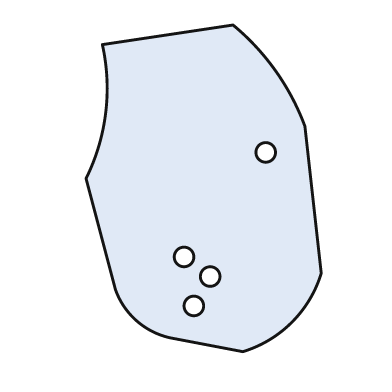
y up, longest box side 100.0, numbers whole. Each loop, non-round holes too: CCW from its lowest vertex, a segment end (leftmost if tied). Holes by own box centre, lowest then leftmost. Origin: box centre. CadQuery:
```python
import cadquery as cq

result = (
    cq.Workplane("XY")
    .moveTo(12.0, -50.0)
    .threePointArc((27.0, -41.0), (36.0, -26.0))
    .lineTo(31.0, 19.0)
    .threePointArc((22.0, 36.0), (9.0, 50.0))
    .lineTo(-31.0, 44.0)
    .threePointArc((-30.0, 23.0), (-36.0, 3.0))
    .lineTo(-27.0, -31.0)
    .threePointArc((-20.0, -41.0), (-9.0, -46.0))
    .close()
    .moveTo(-3.0, -36.0)
    .circle(3.0)
    .moveTo(2.0, -27.0)
    .circle(3.0)
    .moveTo(-6.0, -21.0)
    .circle(3.0)
    .moveTo(19.0, 11.0)
    .circle(3.0)
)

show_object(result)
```